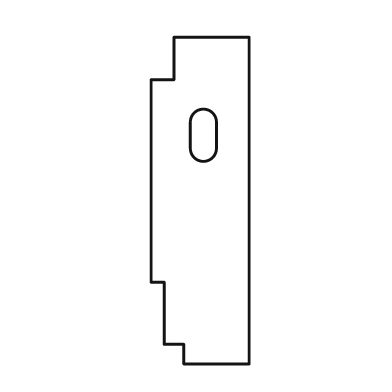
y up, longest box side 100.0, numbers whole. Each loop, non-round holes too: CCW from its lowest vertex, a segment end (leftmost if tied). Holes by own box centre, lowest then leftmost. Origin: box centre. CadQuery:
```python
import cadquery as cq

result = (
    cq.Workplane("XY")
    .moveTo(-5.0, -50.0)
    .lineTo(15.0, -50.0)
    .lineTo(15.0, 50.0)
    .lineTo(-8.0, 50.0)
    .lineTo(-8.0, 37.0)
    .lineTo(-15.0, 37.0)
    .lineTo(-15.0, -25.0)
    .lineTo(-11.0, -25.0)
    .lineTo(-11.0, -44.0)
    .lineTo(-5.0, -44.0)
    .close()
    .moveTo(-3.0, 16.0)
    .threePointArc((1.0, 12.0), (5.0, 16.0))
    .lineTo(5.0, 24.0)
    .threePointArc((1.0, 28.0), (-3.0, 24.0))
    .close()
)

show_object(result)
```